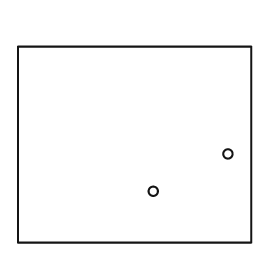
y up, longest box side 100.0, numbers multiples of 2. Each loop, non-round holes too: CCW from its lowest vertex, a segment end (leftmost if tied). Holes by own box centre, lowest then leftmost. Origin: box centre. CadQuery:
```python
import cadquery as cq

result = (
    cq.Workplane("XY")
    .moveTo(-50.0, -42.0)
    .lineTo(50.0, -42.0)
    .lineTo(50.0, 42.0)
    .lineTo(-50.0, 42.0)
    .close()
    .moveTo(8.0, -20.0)
    .circle(2.0)
    .moveTo(40.0, -4.0)
    .circle(2.0)
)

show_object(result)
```